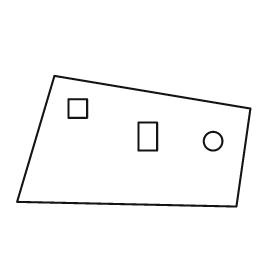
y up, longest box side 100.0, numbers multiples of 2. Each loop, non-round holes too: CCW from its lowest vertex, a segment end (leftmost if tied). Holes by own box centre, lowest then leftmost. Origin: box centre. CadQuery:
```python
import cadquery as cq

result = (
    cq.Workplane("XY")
    .moveTo(44.0, -28.0)
    .lineTo(50.0, 14.0)
    .lineTo(-34.0, 28.0)
    .lineTo(-50.0, -26.0)
    .close()
    .moveTo(34.0, 0.0)
    .circle(4.0)
    .moveTo(2.0, -4.0)
    .lineTo(10.0, -4.0)
    .lineTo(10.0, 8.0)
    .lineTo(2.0, 8.0)
    .close()
    .moveTo(-28.0, 10.0)
    .lineTo(-20.0, 10.0)
    .lineTo(-20.0, 18.0)
    .lineTo(-28.0, 18.0)
    .close()
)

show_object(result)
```